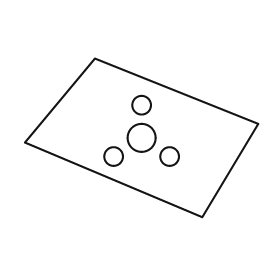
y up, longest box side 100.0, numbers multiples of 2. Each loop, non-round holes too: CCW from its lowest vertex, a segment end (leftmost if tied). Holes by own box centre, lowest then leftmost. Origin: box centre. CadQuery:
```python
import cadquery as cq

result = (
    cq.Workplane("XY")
    .moveTo(26.0, -34.0)
    .lineTo(50.0, 6.0)
    .lineTo(-20.0, 34.0)
    .lineTo(-50.0, -2.0)
    .close()
    .moveTo(-12.0, -8.0)
    .circle(4.0)
    .moveTo(12.0, -8.0)
    .circle(4.0)
    .moveTo(0.0, 0.0)
    .circle(6.0)
    .moveTo(0.0, 14.0)
    .circle(4.0)
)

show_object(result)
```